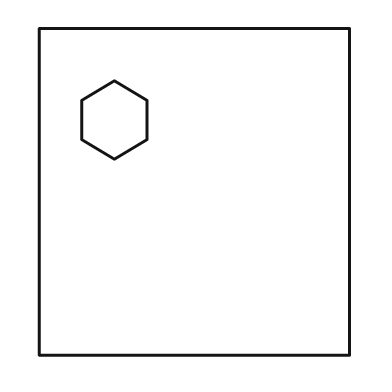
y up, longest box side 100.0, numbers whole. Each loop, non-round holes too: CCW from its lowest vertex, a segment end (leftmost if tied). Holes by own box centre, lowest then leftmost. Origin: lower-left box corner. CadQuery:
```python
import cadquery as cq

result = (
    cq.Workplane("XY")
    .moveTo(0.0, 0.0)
    .lineTo(95.0, 0.0)
    .lineTo(95.0, 100.0)
    .lineTo(0.0, 100.0)
    .close()
    .moveTo(23.0, 60.0)
    .lineTo(33.0, 66.0)
    .lineTo(33.0, 78.0)
    .lineTo(23.0, 84.0)
    .lineTo(13.0, 78.0)
    .lineTo(13.0, 66.0)
    .close()
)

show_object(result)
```